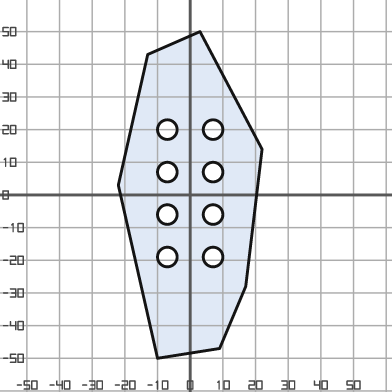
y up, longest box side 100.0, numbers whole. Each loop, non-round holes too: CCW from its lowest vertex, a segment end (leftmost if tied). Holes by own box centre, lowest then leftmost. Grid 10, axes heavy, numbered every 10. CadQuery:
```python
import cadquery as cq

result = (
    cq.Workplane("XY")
    .moveTo(-10.0, -50.0)
    .lineTo(9.0, -47.0)
    .lineTo(17.0, -28.0)
    .lineTo(22.0, 14.0)
    .lineTo(3.0, 50.0)
    .lineTo(-13.0, 43.0)
    .lineTo(-22.0, 3.0)
    .close()
    .moveTo(-7.0, -19.0)
    .circle(3.0)
    .moveTo(7.0, -19.0)
    .circle(3.0)
    .moveTo(-7.0, -6.0)
    .circle(3.0)
    .moveTo(7.0, -6.0)
    .circle(3.0)
    .moveTo(-7.0, 7.0)
    .circle(3.0)
    .moveTo(7.0, 7.0)
    .circle(3.0)
    .moveTo(-7.0, 20.0)
    .circle(3.0)
    .moveTo(7.0, 20.0)
    .circle(3.0)
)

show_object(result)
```